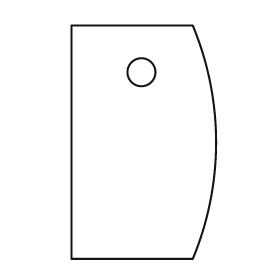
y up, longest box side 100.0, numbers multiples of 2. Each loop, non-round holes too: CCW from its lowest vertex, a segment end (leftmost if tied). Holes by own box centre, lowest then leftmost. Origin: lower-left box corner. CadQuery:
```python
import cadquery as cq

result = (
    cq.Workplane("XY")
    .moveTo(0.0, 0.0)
    .lineTo(52.0, 0.0)
    .threePointArc((62.0, 50.0), (52.0, 100.0))
    .lineTo(0.0, 100.0)
    .close()
    .moveTo(30.0, 80.0)
    .circle(6.0)
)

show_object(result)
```